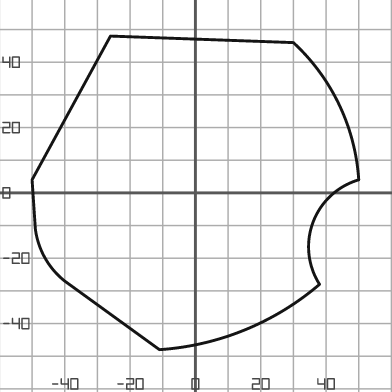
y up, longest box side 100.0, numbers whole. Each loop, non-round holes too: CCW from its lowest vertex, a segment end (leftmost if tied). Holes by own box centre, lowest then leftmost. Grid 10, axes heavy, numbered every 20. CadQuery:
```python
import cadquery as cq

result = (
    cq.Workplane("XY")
    .moveTo(-11.0, -48.0)
    .threePointArc((15.0, -42.0), (38.0, -28.0))
    .threePointArc((36.0, -9.0), (50.0, 4.0))
    .threePointArc((44.0, 27.0), (30.0, 46.0))
    .lineTo(-26.0, 48.0)
    .lineTo(-50.0, 4.0)
    .lineTo(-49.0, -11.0)
    .threePointArc((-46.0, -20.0), (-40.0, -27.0))
    .close()
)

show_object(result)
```